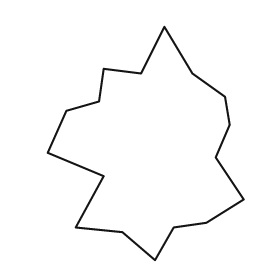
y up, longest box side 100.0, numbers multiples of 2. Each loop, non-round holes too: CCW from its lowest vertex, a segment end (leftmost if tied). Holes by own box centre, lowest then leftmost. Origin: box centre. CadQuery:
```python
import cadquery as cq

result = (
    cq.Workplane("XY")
    .moveTo(4.0, -50.0)
    .lineTo(12.0, -36.0)
    .lineTo(26.0, -34.0)
    .lineTo(42.0, -24.0)
    .lineTo(30.0, -6.0)
    .lineTo(36.0, 8.0)
    .lineTo(34.0, 20.0)
    .lineTo(20.0, 30.0)
    .lineTo(8.0, 50.0)
    .lineTo(-2.0, 30.0)
    .lineTo(-18.0, 32.0)
    .lineTo(-20.0, 18.0)
    .lineTo(-34.0, 14.0)
    .lineTo(-42.0, -4.0)
    .lineTo(-18.0, -14.0)
    .lineTo(-30.0, -36.0)
    .lineTo(-10.0, -38.0)
    .close()
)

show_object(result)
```